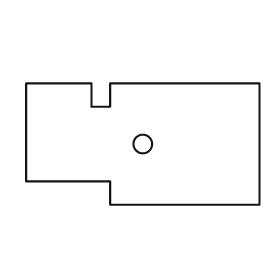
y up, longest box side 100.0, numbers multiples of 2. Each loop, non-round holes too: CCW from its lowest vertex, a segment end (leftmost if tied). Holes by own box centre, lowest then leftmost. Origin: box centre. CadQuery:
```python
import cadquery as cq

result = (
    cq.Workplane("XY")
    .moveTo(-14.0, -26.0)
    .lineTo(50.0, -26.0)
    .lineTo(50.0, 26.0)
    .lineTo(-14.0, 26.0)
    .lineTo(-14.0, 16.0)
    .lineTo(-22.0, 16.0)
    .lineTo(-22.0, 26.0)
    .lineTo(-50.0, 26.0)
    .lineTo(-50.0, -16.0)
    .lineTo(-14.0, -16.0)
    .close()
    .moveTo(0.0, 0.0)
    .circle(4.0)
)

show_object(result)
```